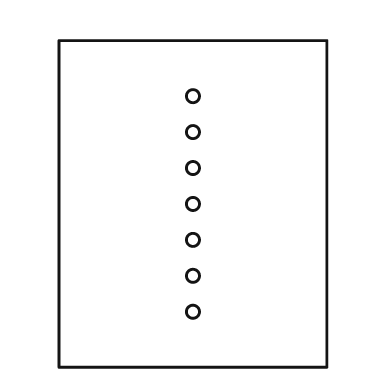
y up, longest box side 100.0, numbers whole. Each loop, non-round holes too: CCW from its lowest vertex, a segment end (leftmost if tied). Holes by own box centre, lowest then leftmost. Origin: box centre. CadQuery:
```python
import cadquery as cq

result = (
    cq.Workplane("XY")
    .moveTo(-41.0, -50.0)
    .lineTo(41.0, -50.0)
    .lineTo(41.0, 50.0)
    .lineTo(-41.0, 50.0)
    .close()
    .moveTo(0.0, -33.0)
    .circle(2.0)
    .moveTo(0.0, -22.0)
    .circle(2.0)
    .moveTo(0.0, -11.0)
    .circle(2.0)
    .moveTo(0.0, 0.0)
    .circle(2.0)
    .moveTo(0.0, 11.0)
    .circle(2.0)
    .moveTo(0.0, 22.0)
    .circle(2.0)
    .moveTo(0.0, 33.0)
    .circle(2.0)
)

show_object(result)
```